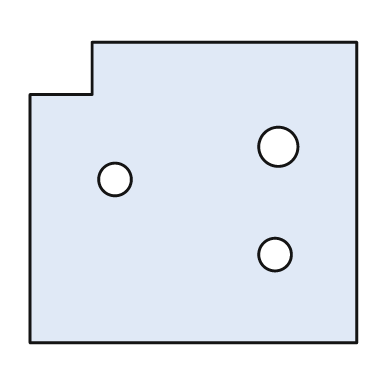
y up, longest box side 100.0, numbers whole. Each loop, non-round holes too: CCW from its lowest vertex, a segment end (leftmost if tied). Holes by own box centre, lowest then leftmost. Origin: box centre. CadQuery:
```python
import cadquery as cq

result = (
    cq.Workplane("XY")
    .moveTo(-50.0, -46.0)
    .lineTo(50.0, -46.0)
    .lineTo(50.0, 46.0)
    .lineTo(-31.0, 46.0)
    .lineTo(-31.0, 30.0)
    .lineTo(-50.0, 30.0)
    .close()
    .moveTo(25.0, -19.0)
    .circle(5.0)
    .moveTo(-24.0, 4.0)
    .circle(5.0)
    .moveTo(26.0, 14.0)
    .circle(6.0)
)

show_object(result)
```